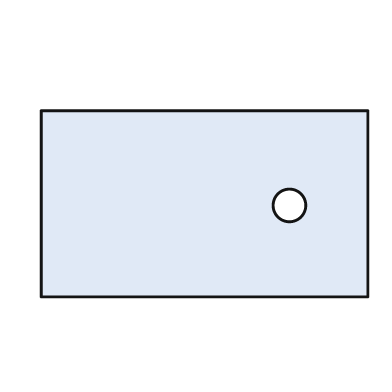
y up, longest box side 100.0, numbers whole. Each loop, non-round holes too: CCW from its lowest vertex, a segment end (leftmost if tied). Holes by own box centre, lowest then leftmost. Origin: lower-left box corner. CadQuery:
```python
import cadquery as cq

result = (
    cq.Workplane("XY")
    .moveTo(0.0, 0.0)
    .lineTo(100.0, 0.0)
    .lineTo(100.0, 57.0)
    .lineTo(0.0, 57.0)
    .close()
    .moveTo(76.0, 28.0)
    .circle(5.0)
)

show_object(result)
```